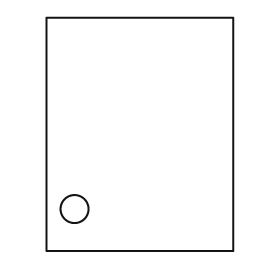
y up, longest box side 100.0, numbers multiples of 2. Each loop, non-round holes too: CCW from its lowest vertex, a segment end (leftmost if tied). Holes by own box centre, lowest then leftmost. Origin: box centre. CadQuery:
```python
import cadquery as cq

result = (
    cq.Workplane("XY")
    .moveTo(-40.0, -50.0)
    .lineTo(40.0, -50.0)
    .lineTo(40.0, 50.0)
    .lineTo(-40.0, 50.0)
    .close()
    .moveTo(-28.0, -32.0)
    .circle(6.0)
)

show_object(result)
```